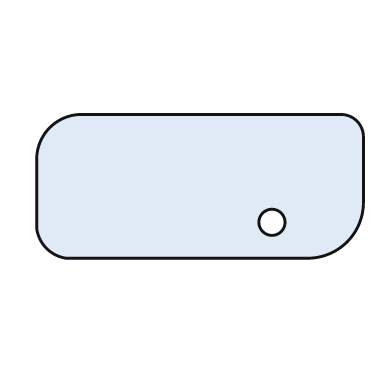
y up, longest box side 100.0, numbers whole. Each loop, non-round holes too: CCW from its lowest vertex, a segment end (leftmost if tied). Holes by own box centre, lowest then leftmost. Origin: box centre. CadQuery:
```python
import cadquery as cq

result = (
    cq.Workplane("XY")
    .moveTo(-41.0, -22.0)
    .lineTo(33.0, -22.0)
    .threePointArc((45.0, -17.0), (50.0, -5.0))
    .lineTo(50.0, 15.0)
    .threePointArc((48.0, 20.0), (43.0, 22.0))
    .lineTo(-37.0, 22.0)
    .threePointArc((-46.0, 18.0), (-50.0, 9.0))
    .lineTo(-50.0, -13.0)
    .threePointArc((-47.0, -19.0), (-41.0, -22.0))
    .close()
    .moveTo(22.0, -11.0)
    .circle(4.0)
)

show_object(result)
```